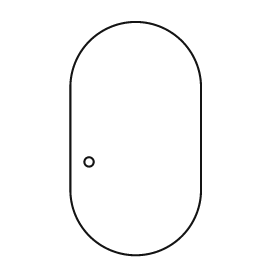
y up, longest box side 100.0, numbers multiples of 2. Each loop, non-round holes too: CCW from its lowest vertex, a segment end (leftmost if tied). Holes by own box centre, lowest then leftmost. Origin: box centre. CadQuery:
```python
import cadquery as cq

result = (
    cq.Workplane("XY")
    .moveTo(-28.0, -22.0)
    .threePointArc((0.0, -50.0), (28.0, -22.0))
    .lineTo(28.0, 22.0)
    .threePointArc((0.0, 50.0), (-28.0, 22.0))
    .close()
    .moveTo(-20.0, -10.0)
    .circle(2.0)
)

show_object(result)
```